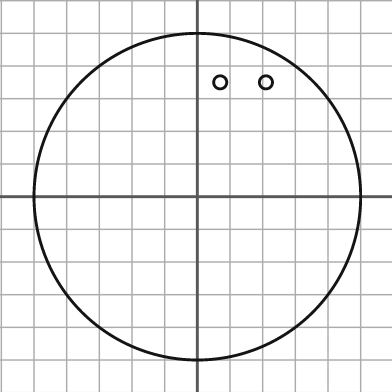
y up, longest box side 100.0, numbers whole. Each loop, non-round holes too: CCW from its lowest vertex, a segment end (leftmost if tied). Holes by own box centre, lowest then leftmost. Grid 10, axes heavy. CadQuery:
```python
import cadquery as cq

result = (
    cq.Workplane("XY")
    .moveTo(0.0, 0.0)
    .circle(50.0)
    .moveTo(7.0, 35.0)
    .circle(2.0)
    .moveTo(21.0, 35.0)
    .circle(2.0)
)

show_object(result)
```